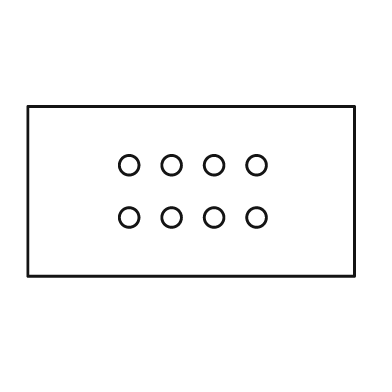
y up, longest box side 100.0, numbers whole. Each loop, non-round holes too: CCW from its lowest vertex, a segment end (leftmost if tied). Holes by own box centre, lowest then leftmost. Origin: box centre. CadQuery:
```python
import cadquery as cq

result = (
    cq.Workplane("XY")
    .moveTo(-50.0, -26.0)
    .lineTo(50.0, -26.0)
    .lineTo(50.0, 26.0)
    .lineTo(-50.0, 26.0)
    .close()
    .moveTo(-19.0, -8.0)
    .circle(3.0)
    .moveTo(-6.0, -8.0)
    .circle(3.0)
    .moveTo(7.0, -8.0)
    .circle(3.0)
    .moveTo(20.0, -8.0)
    .circle(3.0)
    .moveTo(-19.0, 8.0)
    .circle(3.0)
    .moveTo(-6.0, 8.0)
    .circle(3.0)
    .moveTo(7.0, 8.0)
    .circle(3.0)
    .moveTo(20.0, 8.0)
    .circle(3.0)
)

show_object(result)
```